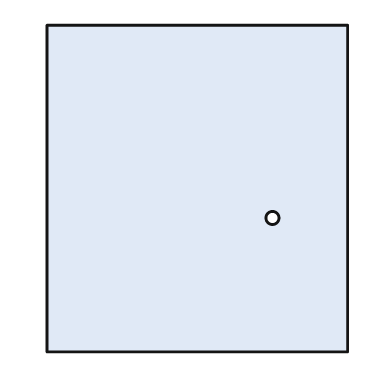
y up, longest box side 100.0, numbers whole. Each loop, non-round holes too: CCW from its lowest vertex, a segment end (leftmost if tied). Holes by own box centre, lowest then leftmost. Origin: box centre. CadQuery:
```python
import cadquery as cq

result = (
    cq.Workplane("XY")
    .moveTo(-46.0, -50.0)
    .lineTo(46.0, -50.0)
    .lineTo(46.0, 50.0)
    .lineTo(-46.0, 50.0)
    .close()
    .moveTo(23.0, -9.0)
    .circle(2.0)
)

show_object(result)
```